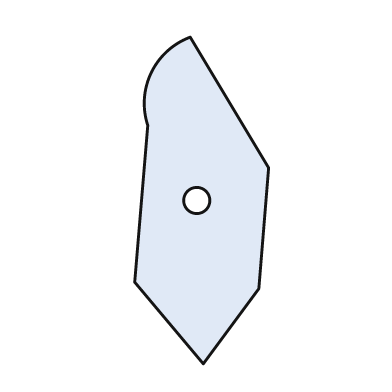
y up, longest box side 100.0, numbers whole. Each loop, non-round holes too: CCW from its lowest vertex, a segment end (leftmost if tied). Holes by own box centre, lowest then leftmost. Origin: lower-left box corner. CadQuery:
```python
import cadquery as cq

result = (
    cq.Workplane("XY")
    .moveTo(21.0, 0.0)
    .lineTo(38.0, 23.0)
    .lineTo(41.0, 60.0)
    .lineTo(17.0, 100.0)
    .threePointArc((5.0, 89.0), (4.0, 73.0))
    .lineTo(0.0, 25.0)
    .close()
    .moveTo(19.0, 50.0)
    .circle(4.0)
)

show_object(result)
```